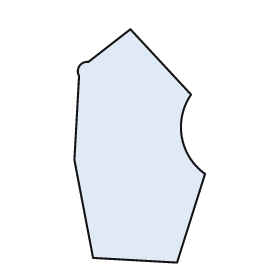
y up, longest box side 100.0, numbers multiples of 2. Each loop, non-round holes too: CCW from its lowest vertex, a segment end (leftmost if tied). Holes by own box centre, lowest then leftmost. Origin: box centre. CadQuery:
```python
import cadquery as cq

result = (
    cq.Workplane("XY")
    .moveTo(16.0, -50.0)
    .lineTo(28.0, -12.0)
    .threePointArc((18.0, 4.0), (22.0, 22.0))
    .lineTo(-4.0, 50.0)
    .lineTo(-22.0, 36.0)
    .threePointArc((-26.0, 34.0), (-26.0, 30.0))
    .lineTo(-28.0, -6.0)
    .lineTo(-20.0, -48.0)
    .close()
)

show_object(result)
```